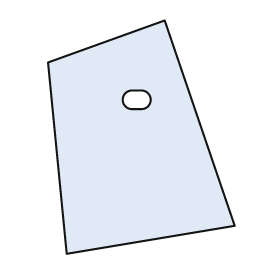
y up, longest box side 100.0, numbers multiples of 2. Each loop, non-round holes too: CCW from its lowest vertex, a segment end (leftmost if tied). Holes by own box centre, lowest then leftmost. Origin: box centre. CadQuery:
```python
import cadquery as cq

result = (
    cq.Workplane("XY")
    .moveTo(-32.0, -50.0)
    .lineTo(40.0, -38.0)
    .lineTo(10.0, 50.0)
    .lineTo(-40.0, 32.0)
    .close()
    .moveTo(-4.0, 12.0)
    .lineTo(0.0, 12.0)
    .threePointArc((4.0, 16.0), (0.0, 20.0))
    .lineTo(-4.0, 20.0)
    .threePointArc((-8.0, 16.0), (-4.0, 12.0))
    .close()
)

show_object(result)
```